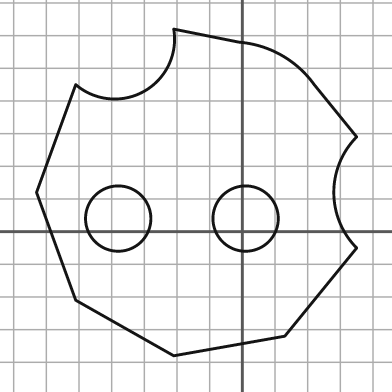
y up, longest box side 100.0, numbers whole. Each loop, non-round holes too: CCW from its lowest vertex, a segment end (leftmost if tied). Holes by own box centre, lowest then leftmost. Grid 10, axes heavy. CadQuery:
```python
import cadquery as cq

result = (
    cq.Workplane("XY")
    .moveTo(-21.0, -38.0)
    .lineTo(13.0, -32.0)
    .lineTo(35.0, -5.0)
    .threePointArc((28.0, 12.0), (35.0, 29.0))
    .lineTo(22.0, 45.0)
    .threePointArc((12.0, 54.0), (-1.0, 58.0))
    .lineTo(-21.0, 62.0)
    .threePointArc((-30.0, 43.0), (-51.0, 45.0))
    .lineTo(-63.0, 12.0)
    .lineTo(-51.0, -21.0)
    .close()
    .moveTo(-38.0, 4.0)
    .circle(10.0)
    .moveTo(1.0, 4.0)
    .circle(10.0)
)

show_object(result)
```